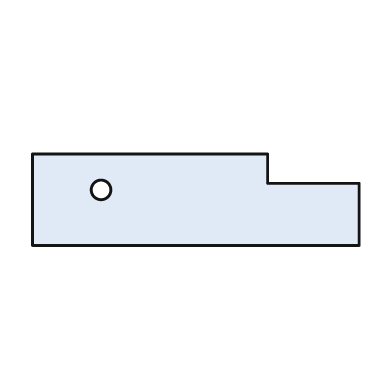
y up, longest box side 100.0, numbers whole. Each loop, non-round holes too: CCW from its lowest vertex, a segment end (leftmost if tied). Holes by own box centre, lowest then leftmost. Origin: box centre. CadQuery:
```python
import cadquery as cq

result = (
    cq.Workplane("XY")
    .moveTo(-50.0, -14.0)
    .lineTo(50.0, -14.0)
    .lineTo(50.0, 5.0)
    .lineTo(22.0, 5.0)
    .lineTo(22.0, 14.0)
    .lineTo(-50.0, 14.0)
    .close()
    .moveTo(-29.0, 3.0)
    .circle(3.0)
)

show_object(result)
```